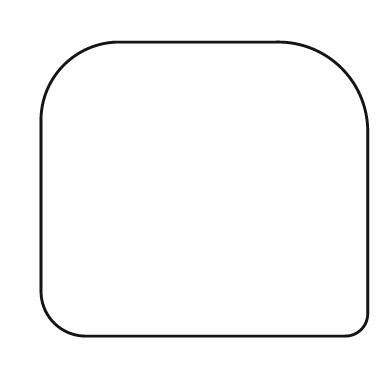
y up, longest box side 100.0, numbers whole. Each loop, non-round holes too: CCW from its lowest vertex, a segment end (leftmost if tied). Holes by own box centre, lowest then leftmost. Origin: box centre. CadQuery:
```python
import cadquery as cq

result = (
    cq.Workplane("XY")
    .moveTo(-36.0, -45.0)
    .lineTo(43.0, -45.0)
    .threePointArc((48.0, -43.0), (50.0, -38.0))
    .lineTo(50.0, 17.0)
    .threePointArc((42.0, 37.0), (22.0, 45.0))
    .lineTo(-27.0, 45.0)
    .threePointArc((-43.0, 38.0), (-50.0, 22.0))
    .lineTo(-50.0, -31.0)
    .threePointArc((-46.0, -41.0), (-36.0, -45.0))
    .close()
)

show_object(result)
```